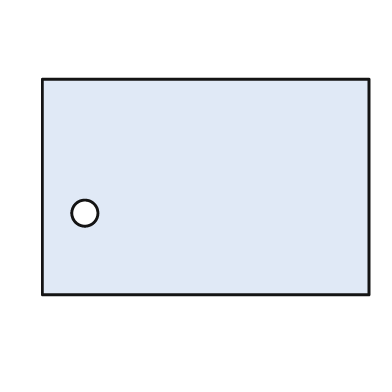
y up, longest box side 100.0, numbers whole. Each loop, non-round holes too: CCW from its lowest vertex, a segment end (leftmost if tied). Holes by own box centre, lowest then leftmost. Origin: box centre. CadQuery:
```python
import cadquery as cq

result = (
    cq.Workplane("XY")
    .moveTo(-50.0, -33.0)
    .lineTo(50.0, -33.0)
    .lineTo(50.0, 33.0)
    .lineTo(-50.0, 33.0)
    .close()
    .moveTo(-37.0, -8.0)
    .circle(4.0)
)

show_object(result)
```